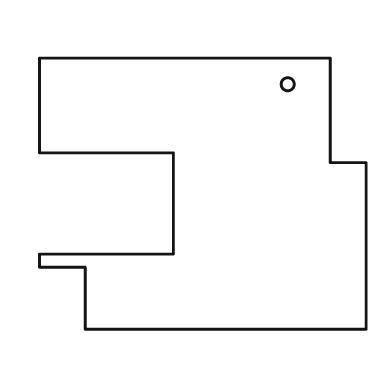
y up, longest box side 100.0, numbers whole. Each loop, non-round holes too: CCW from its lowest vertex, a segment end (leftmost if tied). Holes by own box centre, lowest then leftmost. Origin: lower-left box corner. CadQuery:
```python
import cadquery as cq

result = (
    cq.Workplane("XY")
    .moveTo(14.0, 0.0)
    .lineTo(100.0, 0.0)
    .lineTo(100.0, 51.0)
    .lineTo(89.0, 51.0)
    .lineTo(89.0, 83.0)
    .lineTo(0.0, 83.0)
    .lineTo(0.0, 54.0)
    .lineTo(41.0, 54.0)
    .lineTo(41.0, 23.0)
    .lineTo(0.0, 23.0)
    .lineTo(0.0, 19.0)
    .lineTo(14.0, 19.0)
    .close()
    .moveTo(76.0, 75.0)
    .circle(2.0)
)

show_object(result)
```